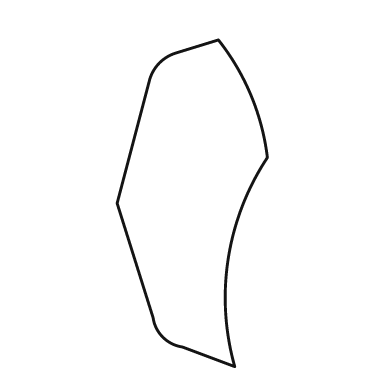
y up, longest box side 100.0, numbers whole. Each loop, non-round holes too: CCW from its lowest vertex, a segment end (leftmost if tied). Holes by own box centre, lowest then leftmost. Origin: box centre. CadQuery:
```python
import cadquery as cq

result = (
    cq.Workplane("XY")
    .moveTo(13.0, -50.0)
    .threePointArc((11.0, -17.0), (23.0, 14.0))
    .threePointArc((18.0, 33.0), (8.0, 50.0))
    .lineTo(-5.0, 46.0)
    .threePointArc((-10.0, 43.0), (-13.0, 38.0))
    .lineTo(-23.0, 0.0)
    .lineTo(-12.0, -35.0)
    .threePointArc((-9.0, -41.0), (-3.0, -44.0))
    .close()
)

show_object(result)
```